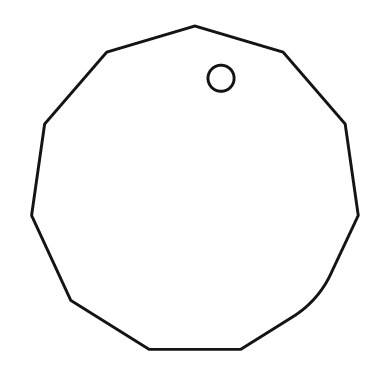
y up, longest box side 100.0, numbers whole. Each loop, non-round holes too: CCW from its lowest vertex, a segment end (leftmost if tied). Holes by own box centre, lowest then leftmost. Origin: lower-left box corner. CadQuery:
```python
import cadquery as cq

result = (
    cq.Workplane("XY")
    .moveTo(36.0, 0.0)
    .lineTo(64.0, 0.0)
    .lineTo(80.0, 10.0)
    .threePointArc((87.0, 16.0), (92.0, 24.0))
    .lineTo(100.0, 41.0)
    .lineTo(96.0, 69.0)
    .lineTo(77.0, 91.0)
    .lineTo(50.0, 99.0)
    .lineTo(23.0, 91.0)
    .lineTo(4.0, 69.0)
    .lineTo(0.0, 41.0)
    .lineTo(12.0, 15.0)
    .close()
    .moveTo(58.0, 83.0)
    .circle(4.0)
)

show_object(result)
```